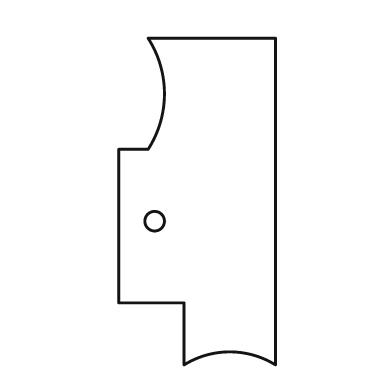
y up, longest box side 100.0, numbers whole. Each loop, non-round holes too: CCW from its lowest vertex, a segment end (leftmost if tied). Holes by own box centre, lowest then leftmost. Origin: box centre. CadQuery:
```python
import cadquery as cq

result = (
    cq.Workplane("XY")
    .moveTo(-4.0, -50.0)
    .threePointArc((10.0, -46.0), (24.0, -50.0))
    .lineTo(24.0, 50.0)
    .lineTo(-15.0, 50.0)
    .threePointArc((-10.0, 33.0), (-15.0, 16.0))
    .lineTo(-24.0, 16.0)
    .lineTo(-24.0, -31.0)
    .lineTo(-4.0, -31.0)
    .close()
    .moveTo(-13.0, -6.0)
    .circle(3.0)
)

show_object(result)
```